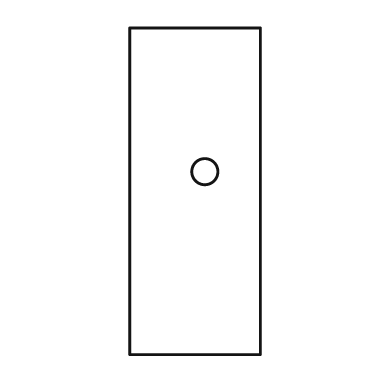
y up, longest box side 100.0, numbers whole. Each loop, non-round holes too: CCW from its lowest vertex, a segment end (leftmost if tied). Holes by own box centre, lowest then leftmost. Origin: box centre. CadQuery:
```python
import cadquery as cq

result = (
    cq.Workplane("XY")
    .moveTo(-20.0, -50.0)
    .lineTo(20.0, -50.0)
    .lineTo(20.0, 50.0)
    .lineTo(-20.0, 50.0)
    .close()
    .moveTo(3.0, 6.0)
    .circle(4.0)
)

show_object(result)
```